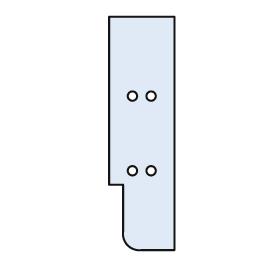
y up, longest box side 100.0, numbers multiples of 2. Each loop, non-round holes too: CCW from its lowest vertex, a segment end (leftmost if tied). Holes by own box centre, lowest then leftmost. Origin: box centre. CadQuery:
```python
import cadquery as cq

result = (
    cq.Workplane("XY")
    .moveTo(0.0, -50.0)
    .lineTo(14.0, -50.0)
    .lineTo(14.0, 50.0)
    .lineTo(-14.0, 50.0)
    .lineTo(-14.0, -22.0)
    .lineTo(-8.0, -22.0)
    .lineTo(-8.0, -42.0)
    .threePointArc((-6.0, -48.0), (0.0, -50.0))
    .close()
    .moveTo(-4.0, -16.0)
    .circle(2.0)
    .moveTo(4.0, -16.0)
    .circle(2.0)
    .moveTo(-4.0, 16.0)
    .circle(2.0)
    .moveTo(4.0, 16.0)
    .circle(2.0)
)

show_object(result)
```